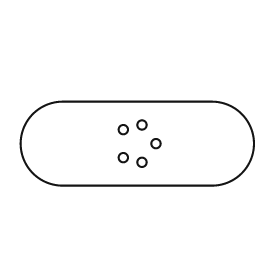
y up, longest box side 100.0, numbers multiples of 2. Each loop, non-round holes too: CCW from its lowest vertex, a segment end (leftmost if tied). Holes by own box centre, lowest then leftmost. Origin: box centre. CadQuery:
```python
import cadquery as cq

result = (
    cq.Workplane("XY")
    .moveTo(-32.0, -18.0)
    .lineTo(32.0, -18.0)
    .threePointArc((50.0, 0.0), (32.0, 18.0))
    .lineTo(-32.0, 18.0)
    .threePointArc((-50.0, 0.0), (-32.0, -18.0))
    .close()
    .moveTo(2.0, -8.0)
    .circle(2.0)
    .moveTo(-6.0, -6.0)
    .circle(2.0)
    .moveTo(8.0, 0.0)
    .circle(2.0)
    .moveTo(-6.0, 6.0)
    .circle(2.0)
    .moveTo(2.0, 8.0)
    .circle(2.0)
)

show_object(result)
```